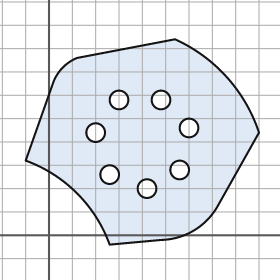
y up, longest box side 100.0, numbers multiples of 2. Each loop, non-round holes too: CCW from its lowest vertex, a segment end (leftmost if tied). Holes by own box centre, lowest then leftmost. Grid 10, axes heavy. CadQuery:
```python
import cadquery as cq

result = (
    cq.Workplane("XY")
    .moveTo(26.0, -4.0)
    .lineTo(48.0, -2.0)
    .threePointArc((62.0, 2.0), (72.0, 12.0))
    .lineTo(90.0, 44.0)
    .threePointArc((76.0, 68.0), (54.0, 84.0))
    .lineTo(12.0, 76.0)
    .threePointArc((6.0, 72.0), (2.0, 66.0))
    .lineTo(-10.0, 32.0)
    .threePointArc((12.0, 18.0), (26.0, -4.0))
    .close()
    .moveTo(42.0, 20.0)
    .circle(4.0)
    .moveTo(26.0, 26.0)
    .circle(4.0)
    .moveTo(56.0, 28.0)
    .circle(4.0)
    .moveTo(20.0, 44.0)
    .circle(4.0)
    .moveTo(60.0, 46.0)
    .circle(4.0)
    .moveTo(30.0, 58.0)
    .circle(4.0)
    .moveTo(48.0, 58.0)
    .circle(4.0)
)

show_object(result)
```